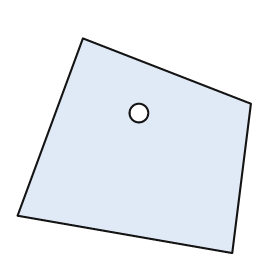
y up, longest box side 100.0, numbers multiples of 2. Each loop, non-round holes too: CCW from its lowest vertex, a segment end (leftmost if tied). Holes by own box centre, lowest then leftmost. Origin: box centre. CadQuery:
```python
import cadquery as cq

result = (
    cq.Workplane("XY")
    .moveTo(42.0, -46.0)
    .lineTo(50.0, 18.0)
    .lineTo(-22.0, 46.0)
    .lineTo(-50.0, -30.0)
    .close()
    .moveTo(2.0, 14.0)
    .circle(4.0)
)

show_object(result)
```